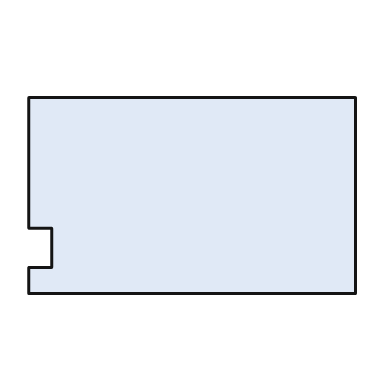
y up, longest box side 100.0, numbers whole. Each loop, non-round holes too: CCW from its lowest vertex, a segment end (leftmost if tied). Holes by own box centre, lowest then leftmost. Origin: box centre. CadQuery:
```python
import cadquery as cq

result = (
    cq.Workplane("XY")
    .moveTo(-50.0, -30.0)
    .lineTo(50.0, -30.0)
    .lineTo(50.0, 30.0)
    .lineTo(-50.0, 30.0)
    .lineTo(-50.0, -10.0)
    .lineTo(-43.0, -10.0)
    .lineTo(-43.0, -22.0)
    .lineTo(-50.0, -22.0)
    .close()
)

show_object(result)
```